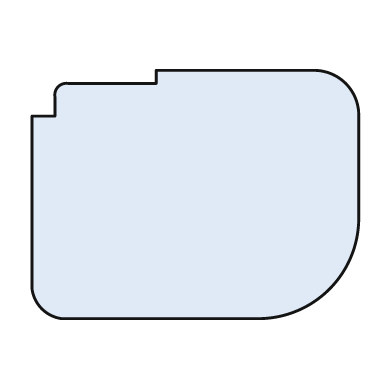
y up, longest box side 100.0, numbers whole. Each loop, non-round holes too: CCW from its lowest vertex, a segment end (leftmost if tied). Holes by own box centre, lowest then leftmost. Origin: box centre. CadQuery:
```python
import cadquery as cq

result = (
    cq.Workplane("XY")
    .moveTo(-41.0, -38.0)
    .lineTo(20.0, -38.0)
    .threePointArc((41.0, -29.0), (50.0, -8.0))
    .lineTo(50.0, 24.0)
    .threePointArc((46.0, 34.0), (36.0, 38.0))
    .lineTo(-12.0, 38.0)
    .lineTo(-12.0, 34.0)
    .lineTo(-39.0, 34.0)
    .threePointArc((-42.0, 33.0), (-43.0, 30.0))
    .lineTo(-43.0, 24.0)
    .lineTo(-50.0, 24.0)
    .lineTo(-50.0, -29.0)
    .threePointArc((-47.0, -35.0), (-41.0, -38.0))
    .close()
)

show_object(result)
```